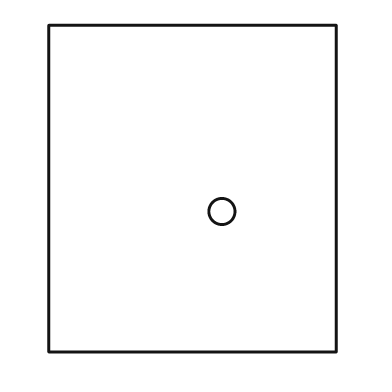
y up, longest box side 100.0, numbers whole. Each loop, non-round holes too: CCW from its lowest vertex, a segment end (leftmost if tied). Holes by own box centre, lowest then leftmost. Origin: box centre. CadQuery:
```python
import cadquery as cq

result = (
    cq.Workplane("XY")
    .moveTo(-44.0, -50.0)
    .lineTo(44.0, -50.0)
    .lineTo(44.0, 50.0)
    .lineTo(-44.0, 50.0)
    .close()
    .moveTo(9.0, -7.0)
    .circle(4.0)
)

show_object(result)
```